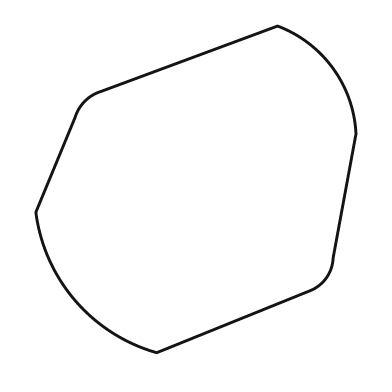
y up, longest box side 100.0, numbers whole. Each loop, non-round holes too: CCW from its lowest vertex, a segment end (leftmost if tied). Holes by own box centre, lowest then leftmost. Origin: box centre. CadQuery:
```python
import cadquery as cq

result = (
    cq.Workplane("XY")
    .moveTo(-12.0, -50.0)
    .lineTo(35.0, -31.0)
    .threePointArc((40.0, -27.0), (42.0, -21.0))
    .lineTo(49.0, 17.0)
    .threePointArc((42.0, 37.0), (25.0, 50.0))
    .lineTo(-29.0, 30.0)
    .threePointArc((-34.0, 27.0), (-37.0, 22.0))
    .lineTo(-49.0, -7.0)
    .threePointArc((-37.0, -34.0), (-12.0, -50.0))
    .close()
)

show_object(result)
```